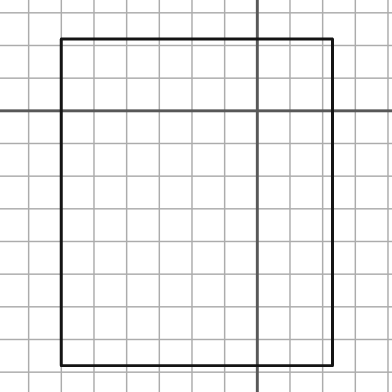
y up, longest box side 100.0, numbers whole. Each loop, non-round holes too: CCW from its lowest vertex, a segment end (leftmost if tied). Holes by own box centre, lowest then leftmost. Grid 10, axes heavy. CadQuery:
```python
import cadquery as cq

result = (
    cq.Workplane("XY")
    .moveTo(-60.0, -78.0)
    .lineTo(23.0, -78.0)
    .lineTo(23.0, 22.0)
    .lineTo(-60.0, 22.0)
    .close()
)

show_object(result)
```